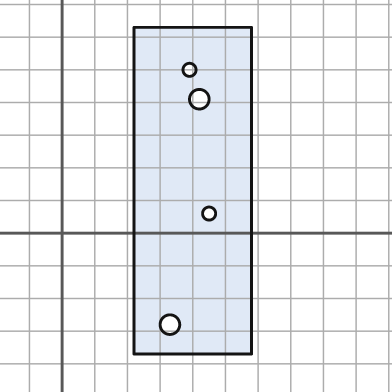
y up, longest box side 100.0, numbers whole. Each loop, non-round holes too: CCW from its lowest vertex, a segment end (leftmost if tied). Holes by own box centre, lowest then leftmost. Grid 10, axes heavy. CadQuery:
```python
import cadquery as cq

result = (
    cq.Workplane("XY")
    .moveTo(22.0, -37.0)
    .lineTo(58.0, -37.0)
    .lineTo(58.0, 63.0)
    .lineTo(22.0, 63.0)
    .close()
    .moveTo(33.0, -28.0)
    .circle(3.0)
    .moveTo(45.0, 6.0)
    .circle(2.0)
    .moveTo(42.0, 41.0)
    .circle(3.0)
    .moveTo(39.0, 50.0)
    .circle(2.0)
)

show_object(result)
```